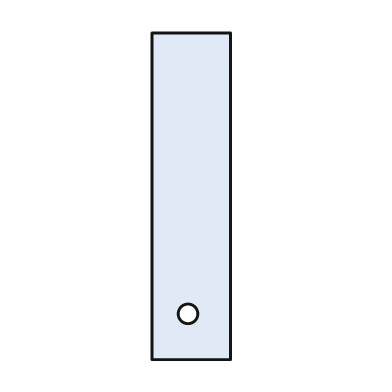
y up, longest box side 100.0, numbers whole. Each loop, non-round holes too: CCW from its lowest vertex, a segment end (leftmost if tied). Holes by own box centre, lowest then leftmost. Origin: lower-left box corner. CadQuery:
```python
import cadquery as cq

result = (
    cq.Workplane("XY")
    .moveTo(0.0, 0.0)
    .lineTo(24.0, 0.0)
    .lineTo(24.0, 100.0)
    .lineTo(0.0, 100.0)
    .close()
    .moveTo(11.0, 14.0)
    .circle(3.0)
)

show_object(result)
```